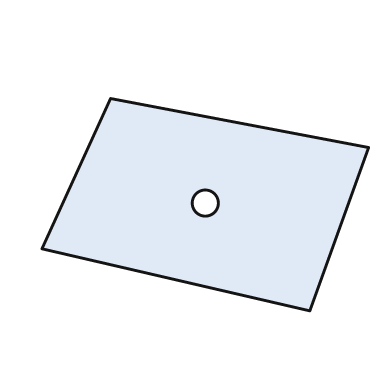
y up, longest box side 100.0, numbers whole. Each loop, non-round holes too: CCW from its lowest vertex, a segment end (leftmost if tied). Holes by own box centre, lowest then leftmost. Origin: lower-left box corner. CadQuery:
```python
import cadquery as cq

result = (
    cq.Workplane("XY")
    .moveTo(82.0, 0.0)
    .lineTo(100.0, 50.0)
    .lineTo(21.0, 65.0)
    .lineTo(0.0, 19.0)
    .close()
    .moveTo(50.0, 33.0)
    .circle(4.0)
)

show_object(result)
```